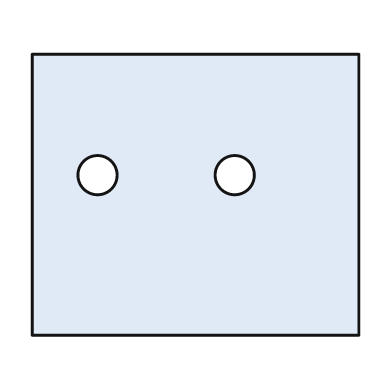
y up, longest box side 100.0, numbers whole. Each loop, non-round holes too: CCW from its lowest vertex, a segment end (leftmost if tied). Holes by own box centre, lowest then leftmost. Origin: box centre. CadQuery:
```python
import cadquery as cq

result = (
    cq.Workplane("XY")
    .moveTo(-50.0, -43.0)
    .lineTo(50.0, -43.0)
    .lineTo(50.0, 43.0)
    .lineTo(-50.0, 43.0)
    .close()
    .moveTo(-30.0, 6.0)
    .circle(6.0)
    .moveTo(12.0, 6.0)
    .circle(6.0)
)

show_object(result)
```